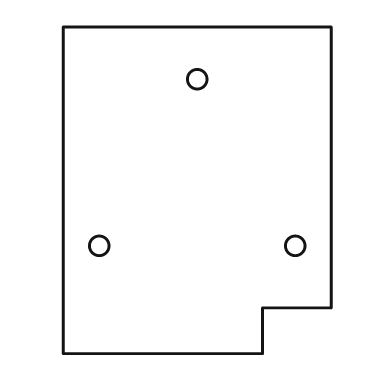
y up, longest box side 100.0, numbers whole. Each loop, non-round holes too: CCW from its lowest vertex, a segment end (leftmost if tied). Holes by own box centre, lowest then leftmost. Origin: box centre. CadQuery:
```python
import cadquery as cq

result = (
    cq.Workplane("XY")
    .moveTo(-41.0, -50.0)
    .lineTo(20.0, -50.0)
    .lineTo(20.0, -36.0)
    .lineTo(41.0, -36.0)
    .lineTo(41.0, 50.0)
    .lineTo(-41.0, 50.0)
    .close()
    .moveTo(-30.0, -17.0)
    .circle(3.0)
    .moveTo(30.0, -17.0)
    .circle(3.0)
    .moveTo(0.0, 34.0)
    .circle(3.0)
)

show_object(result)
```